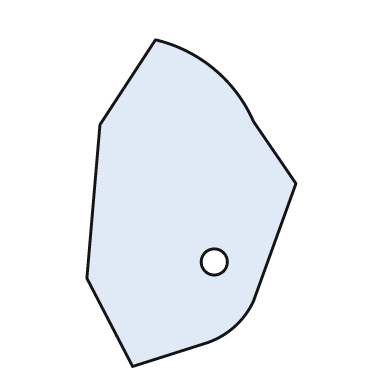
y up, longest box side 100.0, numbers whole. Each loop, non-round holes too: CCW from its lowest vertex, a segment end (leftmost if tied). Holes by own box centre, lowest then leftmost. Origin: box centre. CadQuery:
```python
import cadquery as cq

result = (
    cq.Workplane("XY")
    .moveTo(-18.0, -50.0)
    .lineTo(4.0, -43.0)
    .threePointArc((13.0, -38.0), (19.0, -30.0))
    .lineTo(32.0, 6.0)
    .lineTo(19.0, 25.0)
    .threePointArc((7.0, 41.0), (-11.0, 50.0))
    .lineTo(-28.0, 24.0)
    .lineTo(-32.0, -23.0)
    .close()
    .moveTo(7.0, -18.0)
    .circle(4.0)
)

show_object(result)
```